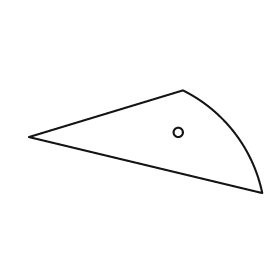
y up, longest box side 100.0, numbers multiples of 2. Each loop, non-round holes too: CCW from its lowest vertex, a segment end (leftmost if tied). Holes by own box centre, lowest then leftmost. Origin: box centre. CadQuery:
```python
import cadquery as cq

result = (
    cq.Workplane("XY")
    .moveTo(50.0, -22.0)
    .threePointArc((38.0, 4.0), (16.0, 22.0))
    .lineTo(-50.0, 2.0)
    .close()
    .moveTo(14.0, 4.0)
    .circle(2.0)
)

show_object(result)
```